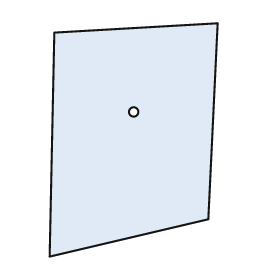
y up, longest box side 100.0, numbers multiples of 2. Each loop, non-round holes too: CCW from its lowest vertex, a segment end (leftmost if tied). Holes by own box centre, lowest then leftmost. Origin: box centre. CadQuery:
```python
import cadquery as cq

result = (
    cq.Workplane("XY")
    .moveTo(-36.0, -50.0)
    .lineTo(32.0, -34.0)
    .lineTo(36.0, 50.0)
    .lineTo(-34.0, 46.0)
    .close()
    .moveTo(0.0, 12.0)
    .circle(2.0)
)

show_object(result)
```